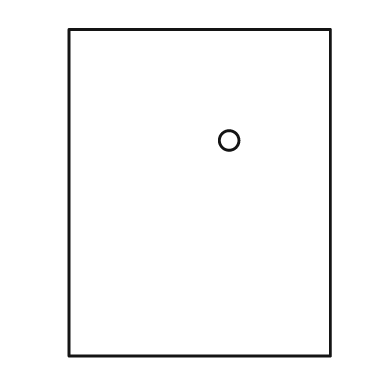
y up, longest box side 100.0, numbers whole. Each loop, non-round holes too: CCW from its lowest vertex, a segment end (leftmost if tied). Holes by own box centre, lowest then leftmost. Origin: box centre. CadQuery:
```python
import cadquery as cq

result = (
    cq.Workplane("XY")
    .moveTo(-40.0, -50.0)
    .lineTo(40.0, -50.0)
    .lineTo(40.0, 50.0)
    .lineTo(-40.0, 50.0)
    .close()
    .moveTo(9.0, 16.0)
    .circle(3.0)
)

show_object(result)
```